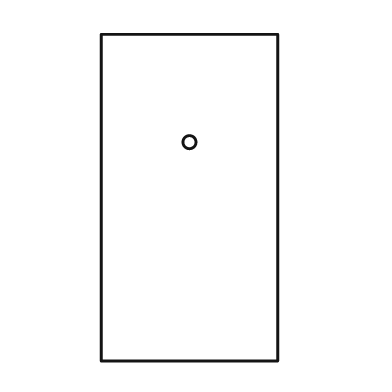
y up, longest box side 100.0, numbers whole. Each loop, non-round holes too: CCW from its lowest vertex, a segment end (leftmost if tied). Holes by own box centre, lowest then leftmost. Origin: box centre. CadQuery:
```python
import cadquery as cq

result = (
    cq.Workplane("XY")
    .moveTo(-27.0, -50.0)
    .lineTo(27.0, -50.0)
    .lineTo(27.0, 50.0)
    .lineTo(-27.0, 50.0)
    .close()
    .moveTo(0.0, 17.0)
    .circle(2.0)
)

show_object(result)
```